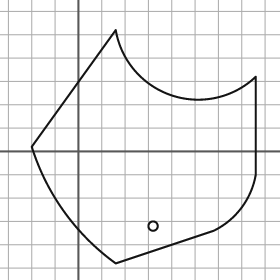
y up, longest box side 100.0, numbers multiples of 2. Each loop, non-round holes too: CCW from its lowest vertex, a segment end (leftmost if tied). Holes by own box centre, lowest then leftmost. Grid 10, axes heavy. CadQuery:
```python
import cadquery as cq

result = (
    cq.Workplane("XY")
    .moveTo(16.0, -48.0)
    .lineTo(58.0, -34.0)
    .threePointArc((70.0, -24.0), (76.0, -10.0))
    .lineTo(76.0, 32.0)
    .threePointArc((40.0, 24.0), (16.0, 52.0))
    .lineTo(-20.0, 2.0)
    .threePointArc((-6.0, -26.0), (16.0, -48.0))
    .close()
    .moveTo(32.0, -32.0)
    .circle(2.0)
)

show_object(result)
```